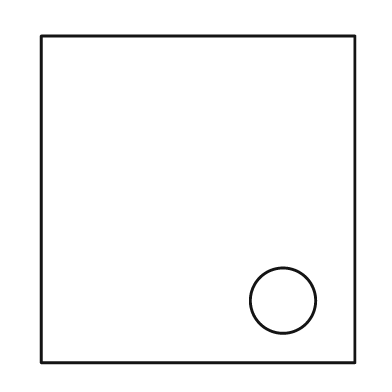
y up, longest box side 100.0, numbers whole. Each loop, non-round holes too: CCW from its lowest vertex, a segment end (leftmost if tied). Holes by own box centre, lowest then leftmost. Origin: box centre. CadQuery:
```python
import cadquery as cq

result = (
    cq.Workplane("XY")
    .moveTo(-48.0, -50.0)
    .lineTo(48.0, -50.0)
    .lineTo(48.0, 50.0)
    .lineTo(-48.0, 50.0)
    .close()
    .moveTo(26.0, -31.0)
    .circle(10.0)
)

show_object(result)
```